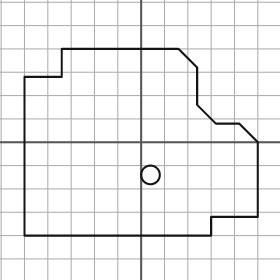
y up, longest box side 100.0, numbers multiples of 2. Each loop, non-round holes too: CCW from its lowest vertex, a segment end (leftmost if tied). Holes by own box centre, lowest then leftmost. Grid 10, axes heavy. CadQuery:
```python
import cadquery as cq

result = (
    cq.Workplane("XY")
    .moveTo(-50.0, -40.0)
    .lineTo(30.0, -40.0)
    .lineTo(30.0, -32.0)
    .lineTo(50.0, -32.0)
    .lineTo(50.0, 0.0)
    .lineTo(42.0, 8.0)
    .lineTo(32.0, 8.0)
    .lineTo(24.0, 16.0)
    .lineTo(24.0, 32.0)
    .lineTo(16.0, 40.0)
    .lineTo(-34.0, 40.0)
    .lineTo(-34.0, 28.0)
    .lineTo(-50.0, 28.0)
    .close()
    .moveTo(4.0, -14.0)
    .circle(4.0)
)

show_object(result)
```